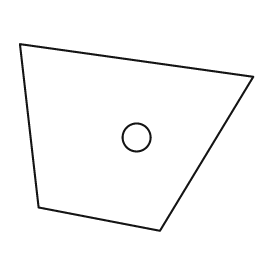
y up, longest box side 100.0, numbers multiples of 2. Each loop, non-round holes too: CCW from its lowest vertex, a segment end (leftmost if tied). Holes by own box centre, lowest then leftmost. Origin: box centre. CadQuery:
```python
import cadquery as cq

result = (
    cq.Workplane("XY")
    .moveTo(10.0, -40.0)
    .lineTo(50.0, 26.0)
    .lineTo(-50.0, 40.0)
    .lineTo(-42.0, -30.0)
    .close()
    .moveTo(0.0, 0.0)
    .circle(6.0)
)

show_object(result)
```